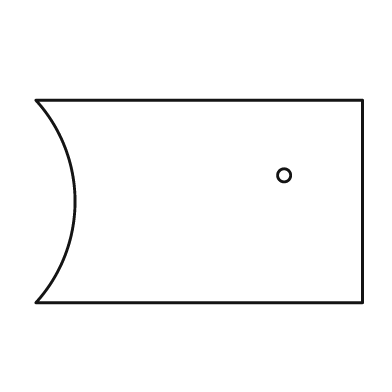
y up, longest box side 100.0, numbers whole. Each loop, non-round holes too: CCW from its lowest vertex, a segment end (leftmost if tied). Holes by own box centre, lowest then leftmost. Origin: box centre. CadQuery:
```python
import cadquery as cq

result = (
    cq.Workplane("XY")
    .moveTo(-50.0, -31.0)
    .lineTo(50.0, -31.0)
    .lineTo(50.0, 31.0)
    .lineTo(-50.0, 31.0)
    .threePointArc((-38.0, 0.0), (-50.0, -31.0))
    .close()
    .moveTo(26.0, 8.0)
    .circle(2.0)
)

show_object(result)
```